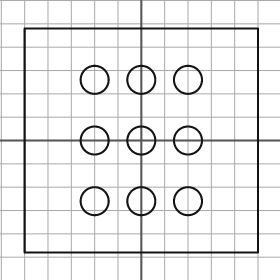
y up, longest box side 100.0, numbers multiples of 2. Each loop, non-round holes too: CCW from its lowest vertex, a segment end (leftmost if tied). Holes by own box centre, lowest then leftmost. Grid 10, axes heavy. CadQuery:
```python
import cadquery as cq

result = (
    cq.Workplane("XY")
    .moveTo(-50.0, -48.0)
    .lineTo(50.0, -48.0)
    .lineTo(50.0, 48.0)
    .lineTo(-50.0, 48.0)
    .close()
    .moveTo(-20.0, -26.0)
    .circle(6.0)
    .moveTo(0.0, -26.0)
    .circle(6.0)
    .moveTo(20.0, -26.0)
    .circle(6.0)
    .moveTo(-20.0, 0.0)
    .circle(6.0)
    .moveTo(0.0, 0.0)
    .circle(6.0)
    .moveTo(20.0, 0.0)
    .circle(6.0)
    .moveTo(-20.0, 26.0)
    .circle(6.0)
    .moveTo(0.0, 26.0)
    .circle(6.0)
    .moveTo(20.0, 26.0)
    .circle(6.0)
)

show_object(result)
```